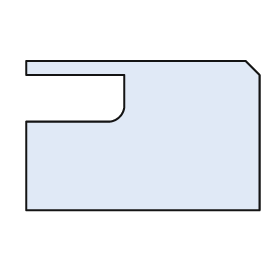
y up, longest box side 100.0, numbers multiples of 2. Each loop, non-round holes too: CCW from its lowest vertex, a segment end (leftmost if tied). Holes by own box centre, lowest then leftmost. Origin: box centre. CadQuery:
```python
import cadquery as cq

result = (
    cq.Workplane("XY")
    .moveTo(-50.0, -32.0)
    .lineTo(50.0, -32.0)
    .lineTo(50.0, 26.0)
    .lineTo(44.0, 32.0)
    .lineTo(-50.0, 32.0)
    .lineTo(-50.0, 26.0)
    .lineTo(-8.0, 26.0)
    .lineTo(-8.0, 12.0)
    .threePointArc((-10.0, 8.0), (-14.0, 6.0))
    .lineTo(-50.0, 6.0)
    .close()
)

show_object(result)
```